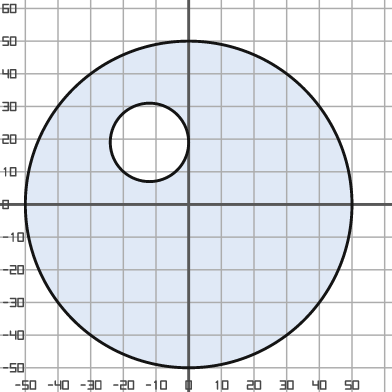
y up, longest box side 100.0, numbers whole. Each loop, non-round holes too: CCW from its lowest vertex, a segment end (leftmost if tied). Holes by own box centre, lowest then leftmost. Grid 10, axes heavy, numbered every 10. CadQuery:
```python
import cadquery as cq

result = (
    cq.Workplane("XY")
    .moveTo(0.0, 0.0)
    .circle(50.0)
    .moveTo(-12.0, 19.0)
    .circle(12.0)
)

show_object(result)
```